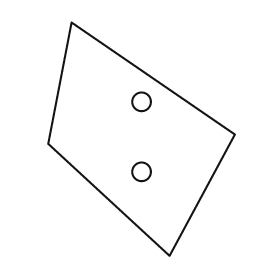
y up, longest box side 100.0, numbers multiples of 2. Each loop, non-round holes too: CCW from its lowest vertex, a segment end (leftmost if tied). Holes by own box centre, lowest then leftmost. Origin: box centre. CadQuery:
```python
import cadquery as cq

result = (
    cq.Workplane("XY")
    .moveTo(12.0, -50.0)
    .lineTo(40.0, 2.0)
    .lineTo(-30.0, 50.0)
    .lineTo(-40.0, -2.0)
    .close()
    .moveTo(0.0, -14.0)
    .circle(4.0)
    .moveTo(0.0, 16.0)
    .circle(4.0)
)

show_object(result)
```